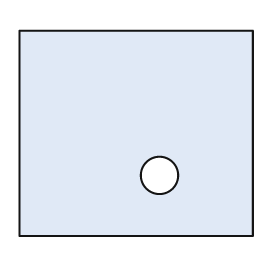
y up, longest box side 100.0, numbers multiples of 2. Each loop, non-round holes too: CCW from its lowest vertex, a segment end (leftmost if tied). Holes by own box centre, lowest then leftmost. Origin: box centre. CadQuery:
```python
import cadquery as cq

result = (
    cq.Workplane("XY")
    .moveTo(-50.0, -44.0)
    .lineTo(50.0, -44.0)
    .lineTo(50.0, 44.0)
    .lineTo(-50.0, 44.0)
    .close()
    .moveTo(10.0, -18.0)
    .circle(8.0)
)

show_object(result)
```